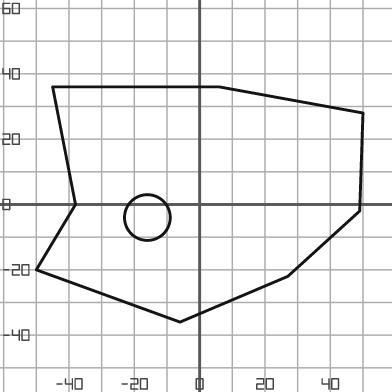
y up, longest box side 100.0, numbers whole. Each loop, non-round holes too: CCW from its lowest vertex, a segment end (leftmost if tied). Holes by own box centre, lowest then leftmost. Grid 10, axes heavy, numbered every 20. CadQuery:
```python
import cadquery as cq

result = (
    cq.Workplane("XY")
    .moveTo(-6.0, -36.0)
    .lineTo(27.0, -22.0)
    .lineTo(49.0, -2.0)
    .lineTo(50.0, 28.0)
    .lineTo(6.0, 36.0)
    .lineTo(-45.0, 36.0)
    .lineTo(-38.0, 0.0)
    .lineTo(-50.0, -20.0)
    .close()
    .moveTo(-16.0, -4.0)
    .circle(7.0)
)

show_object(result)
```